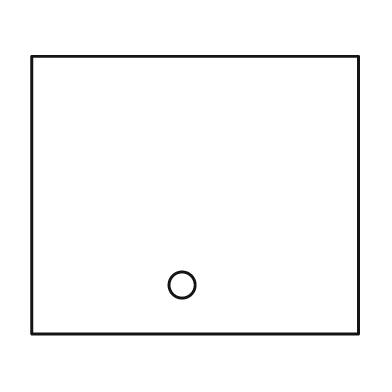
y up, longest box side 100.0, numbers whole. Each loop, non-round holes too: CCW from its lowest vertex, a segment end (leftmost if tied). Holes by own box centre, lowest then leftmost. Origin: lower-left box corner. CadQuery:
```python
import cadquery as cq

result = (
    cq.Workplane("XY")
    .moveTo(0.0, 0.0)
    .lineTo(100.0, 0.0)
    .lineTo(100.0, 85.0)
    .lineTo(0.0, 85.0)
    .close()
    .moveTo(46.0, 15.0)
    .circle(4.0)
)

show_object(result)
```